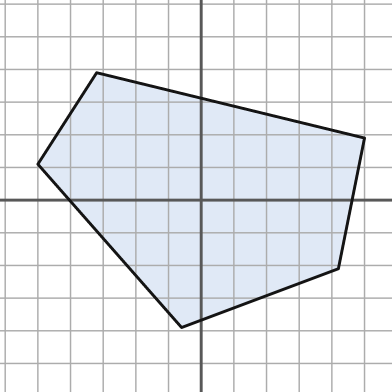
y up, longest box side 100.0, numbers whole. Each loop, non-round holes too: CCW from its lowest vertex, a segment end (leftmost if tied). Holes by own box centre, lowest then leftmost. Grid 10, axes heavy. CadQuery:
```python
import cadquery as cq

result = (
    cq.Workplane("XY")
    .moveTo(-6.0, -39.0)
    .lineTo(42.0, -21.0)
    .lineTo(50.0, 19.0)
    .lineTo(-32.0, 39.0)
    .lineTo(-50.0, 11.0)
    .close()
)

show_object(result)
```